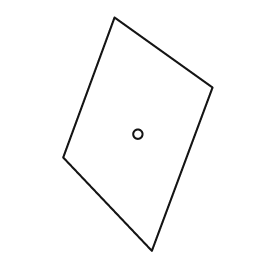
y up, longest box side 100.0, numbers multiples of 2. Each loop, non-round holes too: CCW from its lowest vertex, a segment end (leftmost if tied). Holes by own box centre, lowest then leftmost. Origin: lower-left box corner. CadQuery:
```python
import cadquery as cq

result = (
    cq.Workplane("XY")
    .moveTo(38.0, 0.0)
    .lineTo(64.0, 70.0)
    .lineTo(22.0, 100.0)
    .lineTo(0.0, 40.0)
    .close()
    .moveTo(32.0, 50.0)
    .circle(2.0)
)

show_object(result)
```